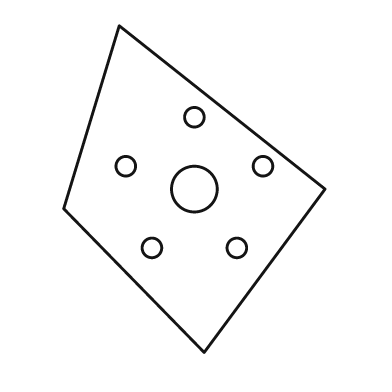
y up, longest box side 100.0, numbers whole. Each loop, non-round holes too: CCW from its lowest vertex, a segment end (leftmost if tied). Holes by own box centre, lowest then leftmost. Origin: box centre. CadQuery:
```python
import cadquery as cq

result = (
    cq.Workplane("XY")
    .moveTo(3.0, -50.0)
    .lineTo(40.0, 0.0)
    .lineTo(-23.0, 50.0)
    .lineTo(-40.0, -6.0)
    .close()
    .moveTo(-13.0, -18.0)
    .circle(3.0)
    .moveTo(13.0, -18.0)
    .circle(3.0)
    .moveTo(0.0, 0.0)
    .circle(7.0)
    .moveTo(-21.0, 7.0)
    .circle(3.0)
    .moveTo(21.0, 7.0)
    .circle(3.0)
    .moveTo(0.0, 22.0)
    .circle(3.0)
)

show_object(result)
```